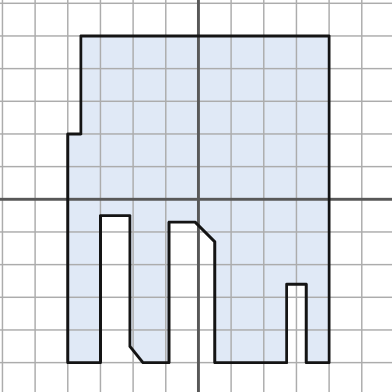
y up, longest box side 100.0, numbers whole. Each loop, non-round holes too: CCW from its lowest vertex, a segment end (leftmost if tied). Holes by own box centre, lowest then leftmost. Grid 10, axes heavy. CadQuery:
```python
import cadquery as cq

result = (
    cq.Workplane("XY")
    .moveTo(-40.0, -50.0)
    .lineTo(-30.0, -50.0)
    .lineTo(-30.0, -5.0)
    .lineTo(-21.0, -5.0)
    .lineTo(-21.0, -45.0)
    .lineTo(-17.0, -50.0)
    .lineTo(-9.0, -50.0)
    .lineTo(-9.0, -7.0)
    .lineTo(-1.0, -7.0)
    .lineTo(5.0, -13.0)
    .lineTo(5.0, -50.0)
    .lineTo(27.0, -50.0)
    .lineTo(27.0, -26.0)
    .lineTo(33.0, -26.0)
    .lineTo(33.0, -50.0)
    .lineTo(40.0, -50.0)
    .lineTo(40.0, 50.0)
    .lineTo(-36.0, 50.0)
    .lineTo(-36.0, 20.0)
    .lineTo(-40.0, 20.0)
    .close()
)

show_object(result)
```